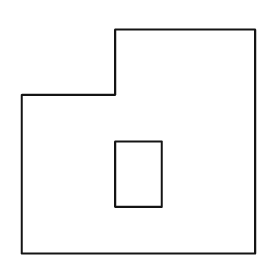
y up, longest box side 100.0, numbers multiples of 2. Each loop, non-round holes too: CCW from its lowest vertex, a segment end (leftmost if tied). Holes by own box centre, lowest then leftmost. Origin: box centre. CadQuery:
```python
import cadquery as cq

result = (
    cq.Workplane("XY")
    .moveTo(-50.0, -48.0)
    .lineTo(50.0, -48.0)
    .lineTo(50.0, 48.0)
    .lineTo(-10.0, 48.0)
    .lineTo(-10.0, 20.0)
    .lineTo(-50.0, 20.0)
    .close()
    .moveTo(-10.0, -28.0)
    .lineTo(10.0, -28.0)
    .lineTo(10.0, 0.0)
    .lineTo(-10.0, 0.0)
    .close()
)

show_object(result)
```